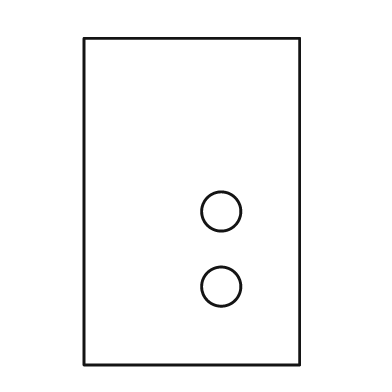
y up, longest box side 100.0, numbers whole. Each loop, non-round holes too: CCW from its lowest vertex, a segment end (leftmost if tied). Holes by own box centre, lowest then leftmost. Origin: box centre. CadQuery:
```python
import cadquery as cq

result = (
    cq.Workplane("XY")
    .moveTo(-33.0, -50.0)
    .lineTo(33.0, -50.0)
    .lineTo(33.0, 50.0)
    .lineTo(-33.0, 50.0)
    .close()
    .moveTo(9.0, -26.0)
    .circle(6.0)
    .moveTo(9.0, -3.0)
    .circle(6.0)
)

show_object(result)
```